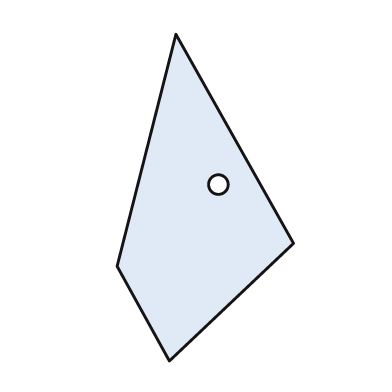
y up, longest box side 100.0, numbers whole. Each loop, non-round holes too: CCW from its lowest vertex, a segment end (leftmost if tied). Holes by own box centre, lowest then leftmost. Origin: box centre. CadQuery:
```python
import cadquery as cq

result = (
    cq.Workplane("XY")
    .moveTo(-11.0, -50.0)
    .lineTo(27.0, -14.0)
    .lineTo(-9.0, 50.0)
    .lineTo(-27.0, -21.0)
    .close()
    .moveTo(4.0, 4.0)
    .circle(3.0)
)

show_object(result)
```